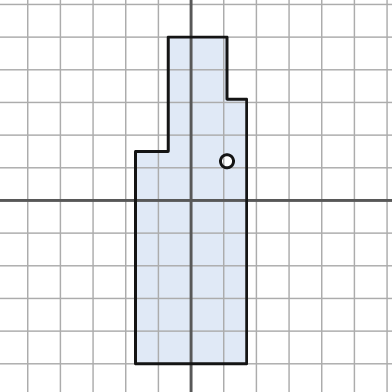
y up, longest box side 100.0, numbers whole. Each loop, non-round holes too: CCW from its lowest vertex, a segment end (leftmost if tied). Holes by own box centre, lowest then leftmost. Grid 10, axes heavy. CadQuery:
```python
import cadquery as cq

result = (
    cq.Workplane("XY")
    .moveTo(-17.0, -50.0)
    .lineTo(17.0, -50.0)
    .lineTo(17.0, 31.0)
    .lineTo(11.0, 31.0)
    .lineTo(11.0, 50.0)
    .lineTo(-7.0, 50.0)
    .lineTo(-7.0, 15.0)
    .lineTo(-17.0, 15.0)
    .close()
    .moveTo(11.0, 12.0)
    .circle(2.0)
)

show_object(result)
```